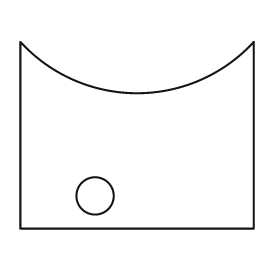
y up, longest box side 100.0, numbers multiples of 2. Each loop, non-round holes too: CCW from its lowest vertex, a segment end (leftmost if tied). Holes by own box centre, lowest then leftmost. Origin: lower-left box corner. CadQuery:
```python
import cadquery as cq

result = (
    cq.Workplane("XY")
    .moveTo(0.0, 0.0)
    .lineTo(100.0, 0.0)
    .lineTo(100.0, 80.0)
    .threePointArc((50.0, 58.0), (0.0, 80.0))
    .close()
    .moveTo(32.0, 14.0)
    .circle(8.0)
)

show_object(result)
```